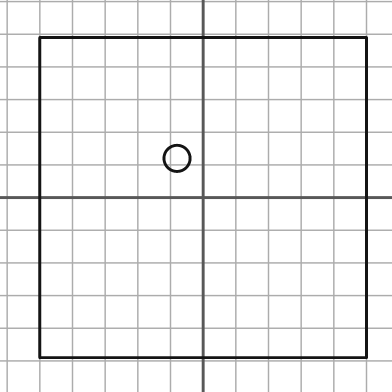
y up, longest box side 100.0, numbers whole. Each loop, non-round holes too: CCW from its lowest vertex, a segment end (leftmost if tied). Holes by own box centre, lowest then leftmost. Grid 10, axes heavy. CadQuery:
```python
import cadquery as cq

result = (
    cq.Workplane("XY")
    .moveTo(-50.0, -49.0)
    .lineTo(50.0, -49.0)
    .lineTo(50.0, 49.0)
    .lineTo(-50.0, 49.0)
    .close()
    .moveTo(-8.0, 12.0)
    .circle(4.0)
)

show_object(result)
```